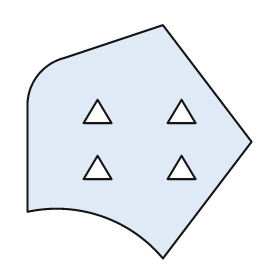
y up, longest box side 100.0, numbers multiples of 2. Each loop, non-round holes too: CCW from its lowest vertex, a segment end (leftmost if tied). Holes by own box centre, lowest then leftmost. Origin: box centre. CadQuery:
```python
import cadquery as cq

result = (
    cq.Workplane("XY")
    .moveTo(10.0, -50.0)
    .lineTo(48.0, 0.0)
    .lineTo(10.0, 50.0)
    .lineTo(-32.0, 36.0)
    .threePointArc((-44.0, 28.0), (-48.0, 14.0))
    .lineTo(-48.0, -30.0)
    .threePointArc((-16.0, -32.0), (10.0, -50.0))
    .close()
    .moveTo(-24.0, -16.0)
    .lineTo(-12.0, -16.0)
    .lineTo(-18.0, -6.0)
    .close()
    .moveTo(12.0, -16.0)
    .lineTo(24.0, -16.0)
    .lineTo(18.0, -6.0)
    .close()
    .moveTo(-24.0, 8.0)
    .lineTo(-12.0, 8.0)
    .lineTo(-18.0, 18.0)
    .close()
    .moveTo(12.0, 8.0)
    .lineTo(24.0, 8.0)
    .lineTo(18.0, 18.0)
    .close()
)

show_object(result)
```